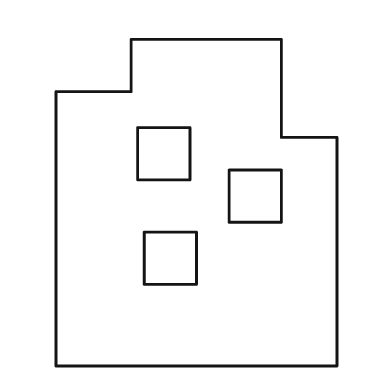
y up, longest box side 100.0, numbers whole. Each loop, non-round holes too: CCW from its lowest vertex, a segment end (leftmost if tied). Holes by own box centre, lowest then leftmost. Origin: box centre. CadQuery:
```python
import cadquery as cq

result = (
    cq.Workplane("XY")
    .moveTo(-43.0, -50.0)
    .lineTo(43.0, -50.0)
    .lineTo(43.0, 20.0)
    .lineTo(26.0, 20.0)
    .lineTo(26.0, 50.0)
    .lineTo(-20.0, 50.0)
    .lineTo(-20.0, 34.0)
    .lineTo(-43.0, 34.0)
    .close()
    .moveTo(-16.0, -25.0)
    .lineTo(0.0, -25.0)
    .lineTo(0.0, -9.0)
    .lineTo(-16.0, -9.0)
    .close()
    .moveTo(10.0, -6.0)
    .lineTo(26.0, -6.0)
    .lineTo(26.0, 10.0)
    .lineTo(10.0, 10.0)
    .close()
    .moveTo(-18.0, 7.0)
    .lineTo(-2.0, 7.0)
    .lineTo(-2.0, 23.0)
    .lineTo(-18.0, 23.0)
    .close()
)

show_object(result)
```